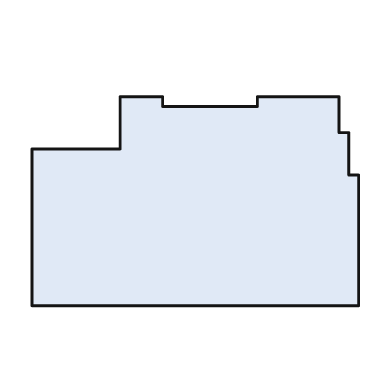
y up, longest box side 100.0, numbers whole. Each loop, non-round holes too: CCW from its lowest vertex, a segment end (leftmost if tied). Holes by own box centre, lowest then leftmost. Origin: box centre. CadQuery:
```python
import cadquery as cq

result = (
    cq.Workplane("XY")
    .moveTo(-50.0, -32.0)
    .lineTo(50.0, -32.0)
    .lineTo(50.0, 8.0)
    .lineTo(47.0, 8.0)
    .lineTo(47.0, 21.0)
    .lineTo(44.0, 21.0)
    .lineTo(44.0, 32.0)
    .lineTo(19.0, 32.0)
    .lineTo(19.0, 29.0)
    .lineTo(-10.0, 29.0)
    .lineTo(-10.0, 32.0)
    .lineTo(-23.0, 32.0)
    .lineTo(-23.0, 16.0)
    .lineTo(-50.0, 16.0)
    .close()
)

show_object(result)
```